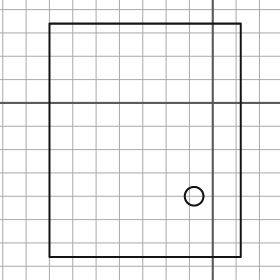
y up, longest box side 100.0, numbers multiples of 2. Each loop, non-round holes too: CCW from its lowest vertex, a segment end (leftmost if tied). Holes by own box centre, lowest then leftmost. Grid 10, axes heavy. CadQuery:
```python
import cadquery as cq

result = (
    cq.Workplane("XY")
    .moveTo(-70.0, -66.0)
    .lineTo(12.0, -66.0)
    .lineTo(12.0, 34.0)
    .lineTo(-70.0, 34.0)
    .close()
    .moveTo(-8.0, -40.0)
    .circle(4.0)
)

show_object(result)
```